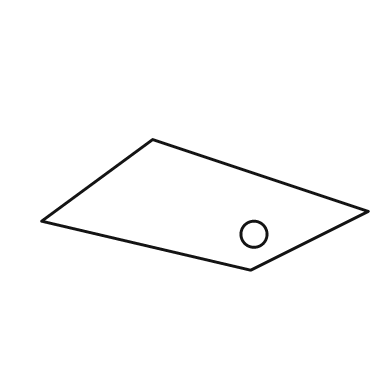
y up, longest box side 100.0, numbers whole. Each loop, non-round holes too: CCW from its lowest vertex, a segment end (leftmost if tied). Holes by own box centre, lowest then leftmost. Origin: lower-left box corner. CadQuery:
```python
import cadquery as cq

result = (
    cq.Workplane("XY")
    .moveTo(64.0, 0.0)
    .lineTo(100.0, 18.0)
    .lineTo(34.0, 40.0)
    .lineTo(0.0, 15.0)
    .close()
    .moveTo(65.0, 11.0)
    .circle(4.0)
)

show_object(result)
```